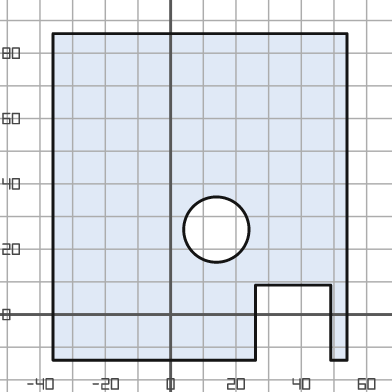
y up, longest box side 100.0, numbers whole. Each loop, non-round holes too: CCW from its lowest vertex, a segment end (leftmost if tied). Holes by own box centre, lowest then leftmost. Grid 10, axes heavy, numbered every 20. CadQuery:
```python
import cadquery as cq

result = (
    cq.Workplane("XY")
    .moveTo(-36.0, -14.0)
    .lineTo(26.0, -14.0)
    .lineTo(26.0, 9.0)
    .lineTo(49.0, 9.0)
    .lineTo(49.0, -14.0)
    .lineTo(54.0, -14.0)
    .lineTo(54.0, 86.0)
    .lineTo(-36.0, 86.0)
    .close()
    .moveTo(14.0, 26.0)
    .circle(10.0)
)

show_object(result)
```